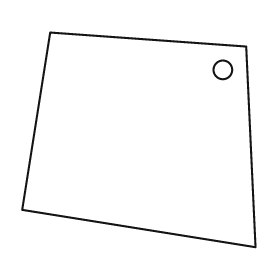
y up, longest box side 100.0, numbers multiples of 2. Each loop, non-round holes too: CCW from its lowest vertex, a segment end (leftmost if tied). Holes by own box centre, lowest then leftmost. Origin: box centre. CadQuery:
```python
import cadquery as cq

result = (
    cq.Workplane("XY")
    .moveTo(50.0, -46.0)
    .lineTo(46.0, 40.0)
    .lineTo(-38.0, 46.0)
    .lineTo(-50.0, -30.0)
    .close()
    .moveTo(36.0, 30.0)
    .circle(4.0)
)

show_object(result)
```